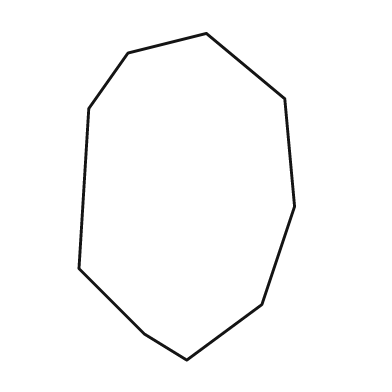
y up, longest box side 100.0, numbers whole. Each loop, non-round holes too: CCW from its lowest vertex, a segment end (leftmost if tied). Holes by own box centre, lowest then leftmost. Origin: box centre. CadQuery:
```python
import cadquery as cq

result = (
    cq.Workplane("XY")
    .moveTo(0.0, -50.0)
    .lineTo(23.0, -33.0)
    .lineTo(33.0, -3.0)
    .lineTo(30.0, 30.0)
    .lineTo(6.0, 50.0)
    .lineTo(-18.0, 44.0)
    .lineTo(-30.0, 27.0)
    .lineTo(-33.0, -22.0)
    .lineTo(-13.0, -42.0)
    .close()
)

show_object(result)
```